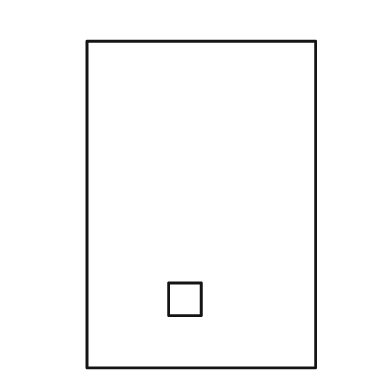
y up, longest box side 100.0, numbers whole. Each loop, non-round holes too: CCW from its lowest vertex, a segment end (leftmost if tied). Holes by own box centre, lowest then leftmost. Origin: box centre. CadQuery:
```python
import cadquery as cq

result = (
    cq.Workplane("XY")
    .moveTo(-35.0, -50.0)
    .lineTo(35.0, -50.0)
    .lineTo(35.0, 50.0)
    .lineTo(-35.0, 50.0)
    .close()
    .moveTo(-10.0, -34.0)
    .lineTo(0.0, -34.0)
    .lineTo(0.0, -24.0)
    .lineTo(-10.0, -24.0)
    .close()
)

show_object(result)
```